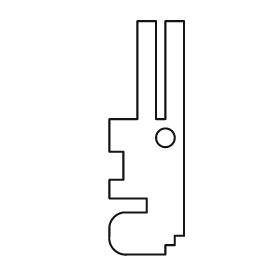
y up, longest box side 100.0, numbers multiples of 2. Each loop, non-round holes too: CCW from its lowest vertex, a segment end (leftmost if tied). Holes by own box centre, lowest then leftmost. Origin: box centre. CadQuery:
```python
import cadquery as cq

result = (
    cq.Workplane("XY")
    .moveTo(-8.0, -50.0)
    .lineTo(8.0, -50.0)
    .lineTo(8.0, -46.0)
    .lineTo(12.0, -46.0)
    .lineTo(12.0, -42.0)
    .lineTo(16.0, -42.0)
    .lineTo(16.0, 50.0)
    .lineTo(8.0, 50.0)
    .lineTo(8.0, 8.0)
    .lineTo(4.0, 8.0)
    .lineTo(4.0, 50.0)
    .lineTo(-4.0, 50.0)
    .lineTo(-4.0, 8.0)
    .lineTo(-16.0, 8.0)
    .lineTo(-16.0, -6.0)
    .lineTo(-10.0, -6.0)
    .lineTo(-10.0, -18.0)
    .lineTo(-16.0, -18.0)
    .lineTo(-16.0, -26.0)
    .lineTo(0.0, -26.0)
    .lineTo(0.0, -32.0)
    .lineTo(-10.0, -32.0)
    .threePointArc((-14.0, -34.0), (-16.0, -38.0))
    .lineTo(-16.0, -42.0)
    .threePointArc((-14.0, -48.0), (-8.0, -50.0))
    .close()
    .moveTo(8.0, 0.0)
    .circle(4.0)
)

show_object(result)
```